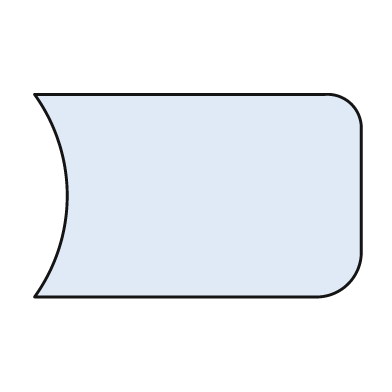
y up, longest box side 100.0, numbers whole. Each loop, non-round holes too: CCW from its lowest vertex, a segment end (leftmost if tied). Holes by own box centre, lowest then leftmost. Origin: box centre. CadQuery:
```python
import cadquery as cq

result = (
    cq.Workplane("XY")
    .moveTo(-50.0, -31.0)
    .lineTo(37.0, -31.0)
    .threePointArc((46.0, -27.0), (50.0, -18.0))
    .lineTo(50.0, 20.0)
    .threePointArc((47.0, 28.0), (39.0, 31.0))
    .lineTo(-50.0, 31.0)
    .threePointArc((-40.0, 0.0), (-50.0, -31.0))
    .close()
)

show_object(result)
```